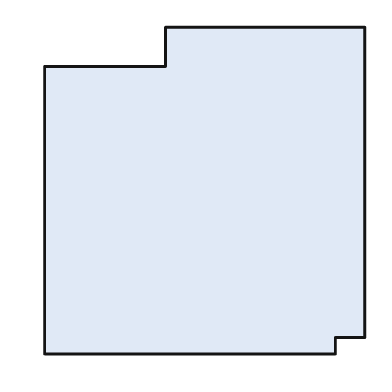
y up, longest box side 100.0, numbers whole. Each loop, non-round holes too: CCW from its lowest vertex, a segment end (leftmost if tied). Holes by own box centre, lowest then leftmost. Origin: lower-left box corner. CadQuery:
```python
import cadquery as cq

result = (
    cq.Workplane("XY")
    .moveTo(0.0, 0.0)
    .lineTo(89.0, 0.0)
    .lineTo(89.0, 5.0)
    .lineTo(98.0, 5.0)
    .lineTo(98.0, 100.0)
    .lineTo(37.0, 100.0)
    .lineTo(37.0, 88.0)
    .lineTo(0.0, 88.0)
    .close()
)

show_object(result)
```